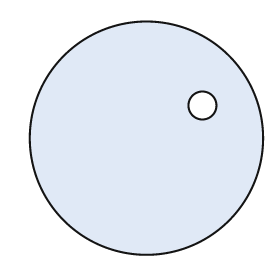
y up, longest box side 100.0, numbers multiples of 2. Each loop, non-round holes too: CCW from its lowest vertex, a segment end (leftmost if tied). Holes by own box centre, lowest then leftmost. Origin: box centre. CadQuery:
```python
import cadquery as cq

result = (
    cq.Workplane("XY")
    .moveTo(0.0, 0.0)
    .circle(50.0)
    .moveTo(24.0, 14.0)
    .circle(6.0)
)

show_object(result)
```